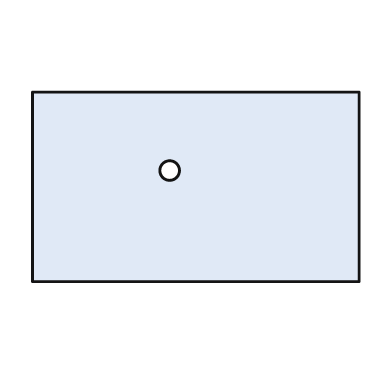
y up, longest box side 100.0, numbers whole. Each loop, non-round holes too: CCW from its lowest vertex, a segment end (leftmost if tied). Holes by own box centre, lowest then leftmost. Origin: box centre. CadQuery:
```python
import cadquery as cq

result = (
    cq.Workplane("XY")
    .moveTo(-50.0, -29.0)
    .lineTo(50.0, -29.0)
    .lineTo(50.0, 29.0)
    .lineTo(-50.0, 29.0)
    .close()
    .moveTo(-8.0, 5.0)
    .circle(3.0)
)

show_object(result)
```